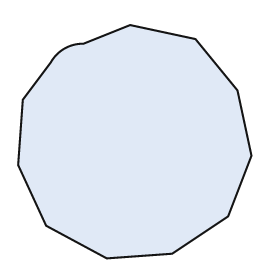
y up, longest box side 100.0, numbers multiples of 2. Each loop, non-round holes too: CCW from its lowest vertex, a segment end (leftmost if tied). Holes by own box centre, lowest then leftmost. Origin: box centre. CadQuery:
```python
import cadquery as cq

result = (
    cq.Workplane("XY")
    .moveTo(-12.0, -50.0)
    .lineTo(16.0, -48.0)
    .lineTo(40.0, -32.0)
    .lineTo(50.0, -6.0)
    .lineTo(44.0, 22.0)
    .lineTo(26.0, 44.0)
    .lineTo(-2.0, 50.0)
    .lineTo(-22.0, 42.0)
    .threePointArc((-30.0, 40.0), (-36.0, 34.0))
    .lineTo(-48.0, 18.0)
    .lineTo(-50.0, -10.0)
    .lineTo(-38.0, -36.0)
    .close()
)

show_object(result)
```